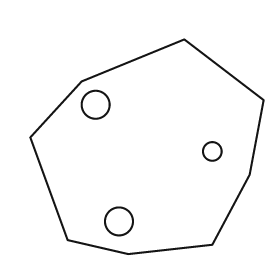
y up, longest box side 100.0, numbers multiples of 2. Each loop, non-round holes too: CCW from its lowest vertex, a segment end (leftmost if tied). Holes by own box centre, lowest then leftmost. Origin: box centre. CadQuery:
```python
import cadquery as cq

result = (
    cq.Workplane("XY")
    .moveTo(-8.0, -46.0)
    .lineTo(28.0, -42.0)
    .lineTo(44.0, -12.0)
    .lineTo(50.0, 20.0)
    .lineTo(16.0, 46.0)
    .lineTo(-28.0, 28.0)
    .lineTo(-50.0, 4.0)
    .lineTo(-34.0, -40.0)
    .close()
    .moveTo(-12.0, -32.0)
    .circle(6.0)
    .moveTo(28.0, -2.0)
    .circle(4.0)
    .moveTo(-22.0, 18.0)
    .circle(6.0)
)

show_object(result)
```